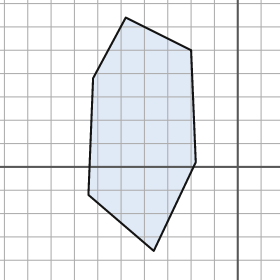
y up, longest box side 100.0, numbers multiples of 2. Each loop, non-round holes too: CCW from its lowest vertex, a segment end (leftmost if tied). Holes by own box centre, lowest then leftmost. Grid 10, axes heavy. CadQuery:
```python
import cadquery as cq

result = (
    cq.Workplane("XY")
    .moveTo(-36.0, -36.0)
    .lineTo(-18.0, 2.0)
    .lineTo(-20.0, 50.0)
    .lineTo(-48.0, 64.0)
    .lineTo(-62.0, 38.0)
    .lineTo(-64.0, -12.0)
    .close()
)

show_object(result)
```